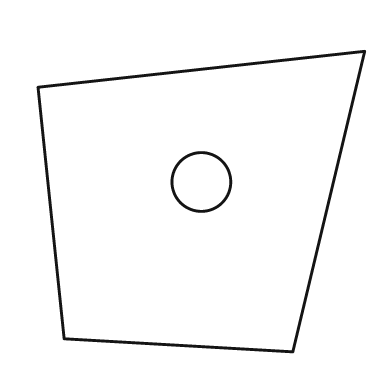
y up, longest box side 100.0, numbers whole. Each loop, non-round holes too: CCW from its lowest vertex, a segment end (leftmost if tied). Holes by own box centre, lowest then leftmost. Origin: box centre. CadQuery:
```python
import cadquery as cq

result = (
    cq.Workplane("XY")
    .moveTo(28.0, -46.0)
    .lineTo(50.0, 46.0)
    .lineTo(-50.0, 35.0)
    .lineTo(-42.0, -42.0)
    .close()
    .moveTo(0.0, 6.0)
    .circle(9.0)
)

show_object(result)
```